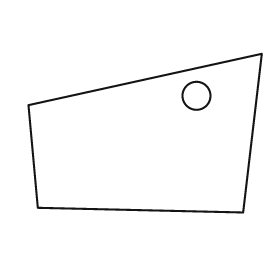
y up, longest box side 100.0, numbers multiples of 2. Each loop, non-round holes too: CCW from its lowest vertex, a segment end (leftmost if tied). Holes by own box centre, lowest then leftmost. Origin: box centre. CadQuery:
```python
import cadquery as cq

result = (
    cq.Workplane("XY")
    .moveTo(42.0, -34.0)
    .lineTo(50.0, 34.0)
    .lineTo(-50.0, 12.0)
    .lineTo(-46.0, -32.0)
    .close()
    .moveTo(22.0, 16.0)
    .circle(6.0)
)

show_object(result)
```